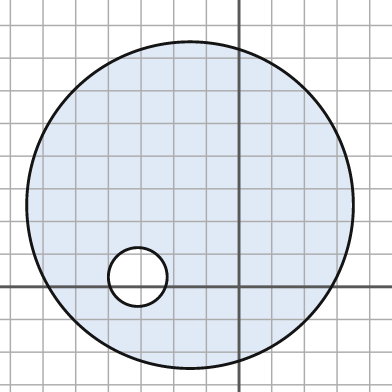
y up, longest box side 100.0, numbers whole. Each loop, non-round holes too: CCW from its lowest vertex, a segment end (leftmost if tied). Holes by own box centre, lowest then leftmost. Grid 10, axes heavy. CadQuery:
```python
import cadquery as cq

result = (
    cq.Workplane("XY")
    .moveTo(-15.0, 25.0)
    .circle(50.0)
    .moveTo(-31.0, 3.0)
    .circle(9.0)
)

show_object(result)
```